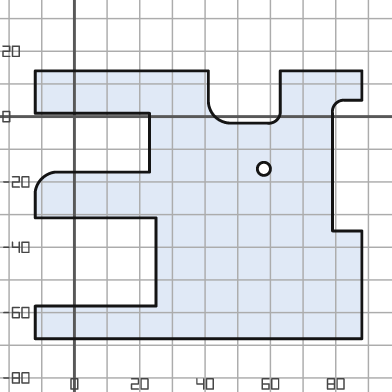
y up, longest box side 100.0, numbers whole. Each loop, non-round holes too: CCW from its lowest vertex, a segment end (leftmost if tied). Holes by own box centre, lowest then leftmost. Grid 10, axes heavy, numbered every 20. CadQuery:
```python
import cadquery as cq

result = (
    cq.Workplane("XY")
    .moveTo(-12.0, -68.0)
    .lineTo(88.0, -68.0)
    .lineTo(88.0, -35.0)
    .lineTo(79.0, -35.0)
    .lineTo(79.0, 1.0)
    .threePointArc((80.0, 4.0), (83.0, 5.0))
    .lineTo(88.0, 5.0)
    .lineTo(88.0, 14.0)
    .lineTo(63.0, 14.0)
    .lineTo(63.0, 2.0)
    .threePointArc((62.0, -1.0), (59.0, -2.0))
    .lineTo(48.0, -2.0)
    .threePointArc((43.0, 0.0), (41.0, 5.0))
    .lineTo(41.0, 14.0)
    .lineTo(-12.0, 14.0)
    .lineTo(-12.0, 1.0)
    .lineTo(23.0, 1.0)
    .lineTo(23.0, -17.0)
    .lineTo(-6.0, -17.0)
    .threePointArc((-10.0, -19.0), (-12.0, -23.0))
    .lineTo(-12.0, -31.0)
    .lineTo(25.0, -31.0)
    .lineTo(25.0, -58.0)
    .lineTo(-12.0, -58.0)
    .close()
    .moveTo(58.0, -16.0)
    .circle(2.0)
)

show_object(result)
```